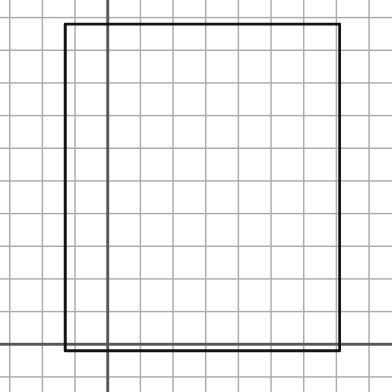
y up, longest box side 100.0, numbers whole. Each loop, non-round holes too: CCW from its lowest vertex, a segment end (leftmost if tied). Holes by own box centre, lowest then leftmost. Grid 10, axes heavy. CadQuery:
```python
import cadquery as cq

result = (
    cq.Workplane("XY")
    .moveTo(-13.0, -2.0)
    .lineTo(71.0, -2.0)
    .lineTo(71.0, 98.0)
    .lineTo(-13.0, 98.0)
    .close()
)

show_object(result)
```